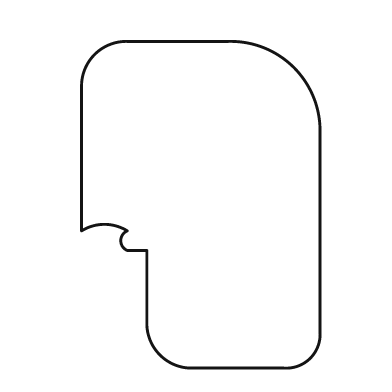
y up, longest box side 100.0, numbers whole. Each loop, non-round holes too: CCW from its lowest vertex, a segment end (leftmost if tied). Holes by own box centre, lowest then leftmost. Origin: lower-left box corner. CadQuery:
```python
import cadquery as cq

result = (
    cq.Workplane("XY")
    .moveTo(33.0, 0.0)
    .lineTo(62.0, 0.0)
    .threePointArc((70.0, 3.0), (73.0, 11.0))
    .lineTo(73.0, 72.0)
    .threePointArc((65.0, 92.0), (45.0, 100.0))
    .lineTo(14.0, 100.0)
    .threePointArc((4.0, 96.0), (0.0, 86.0))
    .lineTo(0.0, 42.0)
    .threePointArc((7.0, 44.0), (14.0, 42.0))
    .threePointArc((12.0, 39.0), (14.0, 36.0))
    .lineTo(20.0, 36.0)
    .lineTo(20.0, 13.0)
    .threePointArc((24.0, 4.0), (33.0, 0.0))
    .close()
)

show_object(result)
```